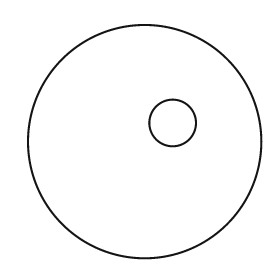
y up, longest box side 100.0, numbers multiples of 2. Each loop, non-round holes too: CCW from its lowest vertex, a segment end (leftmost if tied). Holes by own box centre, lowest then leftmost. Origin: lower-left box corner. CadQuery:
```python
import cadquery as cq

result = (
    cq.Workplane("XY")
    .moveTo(50.0, 50.0)
    .circle(50.0)
    .moveTo(62.0, 58.0)
    .circle(10.0)
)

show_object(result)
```